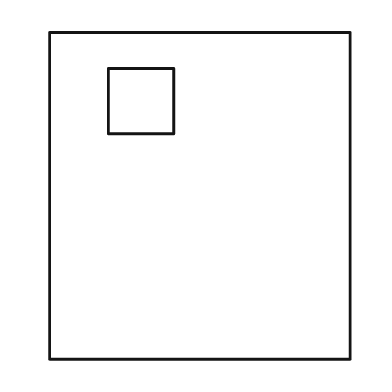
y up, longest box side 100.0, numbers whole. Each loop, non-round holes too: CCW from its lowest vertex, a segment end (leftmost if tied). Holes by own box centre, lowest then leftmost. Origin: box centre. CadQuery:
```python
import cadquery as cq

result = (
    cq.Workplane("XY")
    .moveTo(-46.0, -50.0)
    .lineTo(46.0, -50.0)
    .lineTo(46.0, 50.0)
    .lineTo(-46.0, 50.0)
    .close()
    .moveTo(-28.0, 19.0)
    .lineTo(-8.0, 19.0)
    .lineTo(-8.0, 39.0)
    .lineTo(-28.0, 39.0)
    .close()
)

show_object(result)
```